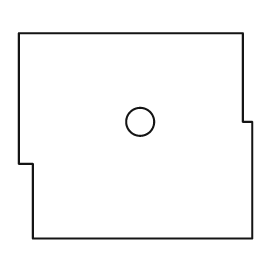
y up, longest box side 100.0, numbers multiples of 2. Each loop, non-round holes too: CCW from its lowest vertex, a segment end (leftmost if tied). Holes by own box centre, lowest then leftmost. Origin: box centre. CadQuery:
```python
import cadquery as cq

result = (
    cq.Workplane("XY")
    .moveTo(-44.0, -44.0)
    .lineTo(50.0, -44.0)
    .lineTo(50.0, 6.0)
    .lineTo(46.0, 6.0)
    .lineTo(46.0, 44.0)
    .lineTo(-50.0, 44.0)
    .lineTo(-50.0, -12.0)
    .lineTo(-44.0, -12.0)
    .close()
    .moveTo(2.0, 6.0)
    .circle(6.0)
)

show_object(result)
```